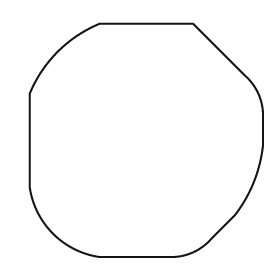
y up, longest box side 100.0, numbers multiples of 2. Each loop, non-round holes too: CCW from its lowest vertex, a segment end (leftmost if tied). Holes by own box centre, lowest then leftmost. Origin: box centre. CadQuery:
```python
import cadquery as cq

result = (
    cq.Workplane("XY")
    .moveTo(-20.0, -50.0)
    .lineTo(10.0, -50.0)
    .threePointArc((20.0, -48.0), (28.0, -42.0))
    .lineTo(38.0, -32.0)
    .threePointArc((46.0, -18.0), (50.0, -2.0))
    .lineTo(50.0, 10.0)
    .threePointArc((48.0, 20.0), (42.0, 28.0))
    .lineTo(20.0, 50.0)
    .lineTo(-20.0, 50.0)
    .threePointArc((-38.0, 38.0), (-50.0, 20.0))
    .lineTo(-50.0, -20.0)
    .threePointArc((-40.0, -40.0), (-20.0, -50.0))
    .close()
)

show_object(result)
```